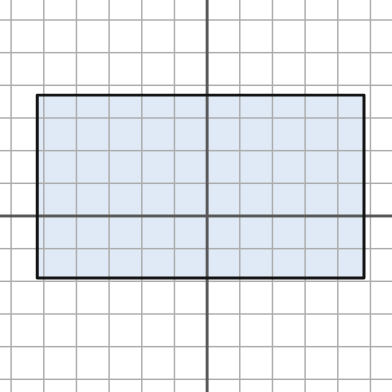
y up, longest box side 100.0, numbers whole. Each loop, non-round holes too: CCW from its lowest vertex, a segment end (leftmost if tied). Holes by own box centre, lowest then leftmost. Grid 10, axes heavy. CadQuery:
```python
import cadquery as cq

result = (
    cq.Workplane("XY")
    .moveTo(-52.0, -19.0)
    .lineTo(48.0, -19.0)
    .lineTo(48.0, 37.0)
    .lineTo(-52.0, 37.0)
    .close()
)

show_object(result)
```